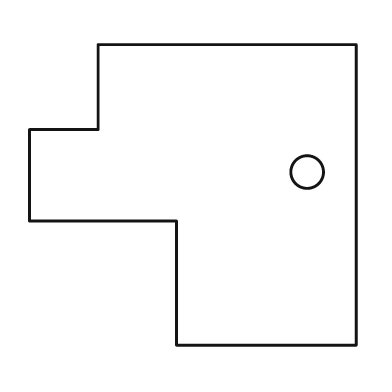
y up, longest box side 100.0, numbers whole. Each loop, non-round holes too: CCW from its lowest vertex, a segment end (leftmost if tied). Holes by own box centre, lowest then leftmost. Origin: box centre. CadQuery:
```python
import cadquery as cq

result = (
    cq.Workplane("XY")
    .moveTo(-5.0, -46.0)
    .lineTo(50.0, -46.0)
    .lineTo(50.0, 46.0)
    .lineTo(-29.0, 46.0)
    .lineTo(-29.0, 20.0)
    .lineTo(-50.0, 20.0)
    .lineTo(-50.0, -8.0)
    .lineTo(-5.0, -8.0)
    .close()
    .moveTo(35.0, 7.0)
    .circle(5.0)
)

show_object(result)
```